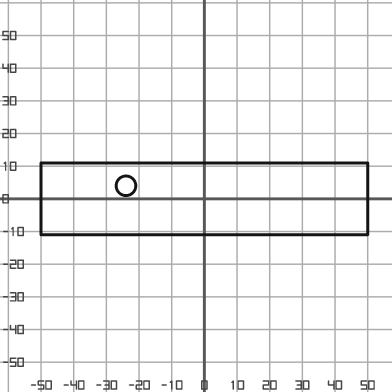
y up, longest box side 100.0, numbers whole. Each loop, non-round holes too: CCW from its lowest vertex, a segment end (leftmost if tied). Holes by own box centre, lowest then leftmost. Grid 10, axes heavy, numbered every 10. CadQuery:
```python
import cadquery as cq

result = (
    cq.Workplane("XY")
    .moveTo(-50.0, -11.0)
    .lineTo(50.0, -11.0)
    .lineTo(50.0, 11.0)
    .lineTo(-50.0, 11.0)
    .close()
    .moveTo(-24.0, 4.0)
    .circle(3.0)
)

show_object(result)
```